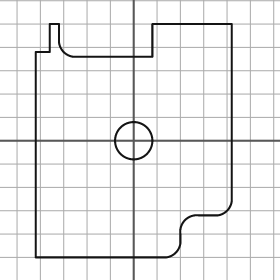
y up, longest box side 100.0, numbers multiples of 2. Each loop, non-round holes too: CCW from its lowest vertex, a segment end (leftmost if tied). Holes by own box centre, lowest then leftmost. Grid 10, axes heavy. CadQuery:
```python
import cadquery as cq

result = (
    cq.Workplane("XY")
    .moveTo(-42.0, -50.0)
    .lineTo(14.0, -50.0)
    .threePointArc((18.0, -48.0), (20.0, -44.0))
    .lineTo(20.0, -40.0)
    .threePointArc((22.0, -34.0), (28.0, -32.0))
    .lineTo(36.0, -32.0)
    .threePointArc((40.0, -30.0), (42.0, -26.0))
    .lineTo(42.0, 50.0)
    .lineTo(8.0, 50.0)
    .lineTo(8.0, 36.0)
    .lineTo(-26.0, 36.0)
    .threePointArc((-30.0, 38.0), (-32.0, 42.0))
    .lineTo(-32.0, 50.0)
    .lineTo(-36.0, 50.0)
    .lineTo(-36.0, 38.0)
    .lineTo(-42.0, 38.0)
    .close()
    .moveTo(0.0, 0.0)
    .circle(8.0)
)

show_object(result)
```